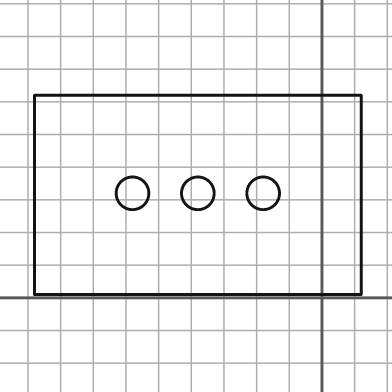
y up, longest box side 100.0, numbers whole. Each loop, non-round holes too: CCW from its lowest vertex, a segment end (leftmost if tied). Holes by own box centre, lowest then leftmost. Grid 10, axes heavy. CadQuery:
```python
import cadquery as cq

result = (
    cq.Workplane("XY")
    .moveTo(-88.0, 1.0)
    .lineTo(12.0, 1.0)
    .lineTo(12.0, 62.0)
    .lineTo(-88.0, 62.0)
    .close()
    .moveTo(-58.0, 32.0)
    .circle(5.0)
    .moveTo(-38.0, 32.0)
    .circle(5.0)
    .moveTo(-18.0, 32.0)
    .circle(5.0)
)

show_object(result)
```